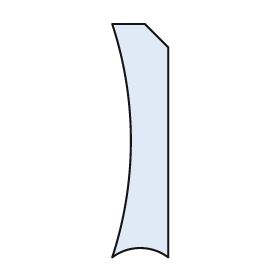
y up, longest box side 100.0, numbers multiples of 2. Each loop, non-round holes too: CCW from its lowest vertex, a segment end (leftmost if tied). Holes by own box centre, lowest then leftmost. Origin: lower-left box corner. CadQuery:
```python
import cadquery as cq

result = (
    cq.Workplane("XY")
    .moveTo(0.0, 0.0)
    .threePointArc((12.0, 4.0), (24.0, 0.0))
    .lineTo(24.0, 90.0)
    .lineTo(14.0, 100.0)
    .lineTo(0.0, 100.0)
    .threePointArc((8.0, 50.0), (0.0, 0.0))
    .close()
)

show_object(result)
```